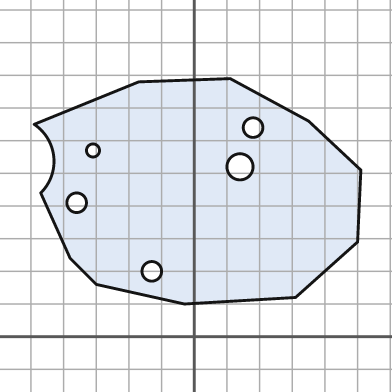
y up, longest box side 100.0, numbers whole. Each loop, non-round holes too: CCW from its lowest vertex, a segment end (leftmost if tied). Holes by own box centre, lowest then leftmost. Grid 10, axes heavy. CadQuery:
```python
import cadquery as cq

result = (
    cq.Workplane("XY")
    .moveTo(-3.0, 10.0)
    .lineTo(31.0, 12.0)
    .lineTo(50.0, 29.0)
    .lineTo(51.0, 51.0)
    .lineTo(35.0, 66.0)
    .lineTo(11.0, 79.0)
    .lineTo(-17.0, 78.0)
    .lineTo(-49.0, 65.0)
    .threePointArc((-43.0, 55.0), (-47.0, 44.0))
    .lineTo(-38.0, 24.0)
    .lineTo(-30.0, 16.0)
    .close()
    .moveTo(-13.0, 20.0)
    .circle(3.0)
    .moveTo(-36.0, 41.0)
    .circle(3.0)
    .moveTo(14.0, 52.0)
    .circle(4.0)
    .moveTo(-31.0, 57.0)
    .circle(2.0)
    .moveTo(18.0, 64.0)
    .circle(3.0)
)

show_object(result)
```